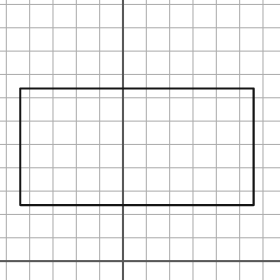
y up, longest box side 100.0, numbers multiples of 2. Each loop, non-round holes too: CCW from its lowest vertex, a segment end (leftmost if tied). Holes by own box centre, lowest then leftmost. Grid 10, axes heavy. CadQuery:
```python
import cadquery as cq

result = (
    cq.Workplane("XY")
    .moveTo(-44.0, 24.0)
    .lineTo(56.0, 24.0)
    .lineTo(56.0, 74.0)
    .lineTo(-44.0, 74.0)
    .close()
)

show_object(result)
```